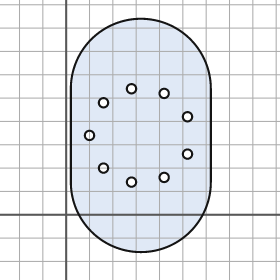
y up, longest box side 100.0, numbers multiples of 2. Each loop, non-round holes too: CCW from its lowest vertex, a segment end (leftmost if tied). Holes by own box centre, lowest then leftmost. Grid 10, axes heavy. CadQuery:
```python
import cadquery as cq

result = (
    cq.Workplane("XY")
    .moveTo(2.0, 14.0)
    .threePointArc((32.0, -16.0), (62.0, 14.0))
    .lineTo(62.0, 54.0)
    .threePointArc((32.0, 84.0), (2.0, 54.0))
    .close()
    .moveTo(28.0, 14.0)
    .circle(2.0)
    .moveTo(42.0, 16.0)
    .circle(2.0)
    .moveTo(16.0, 20.0)
    .circle(2.0)
    .moveTo(52.0, 26.0)
    .circle(2.0)
    .moveTo(10.0, 34.0)
    .circle(2.0)
    .moveTo(52.0, 42.0)
    .circle(2.0)
    .moveTo(16.0, 48.0)
    .circle(2.0)
    .moveTo(42.0, 52.0)
    .circle(2.0)
    .moveTo(28.0, 54.0)
    .circle(2.0)
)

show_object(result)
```